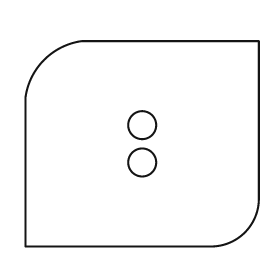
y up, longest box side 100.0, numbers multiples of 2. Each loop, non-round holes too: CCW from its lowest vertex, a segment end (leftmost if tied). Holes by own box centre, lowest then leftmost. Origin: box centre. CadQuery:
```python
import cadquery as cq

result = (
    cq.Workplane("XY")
    .moveTo(-50.0, -44.0)
    .lineTo(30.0, -44.0)
    .threePointArc((44.0, -38.0), (50.0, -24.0))
    .lineTo(50.0, 44.0)
    .lineTo(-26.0, 44.0)
    .threePointArc((-42.0, 36.0), (-50.0, 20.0))
    .close()
    .moveTo(0.0, -8.0)
    .circle(6.0)
    .moveTo(0.0, 8.0)
    .circle(6.0)
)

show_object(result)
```